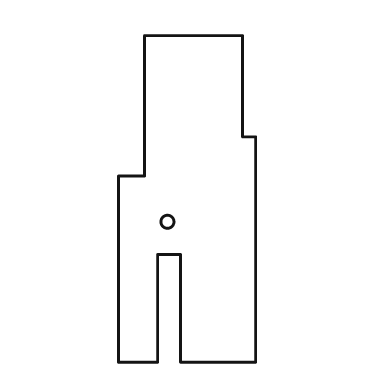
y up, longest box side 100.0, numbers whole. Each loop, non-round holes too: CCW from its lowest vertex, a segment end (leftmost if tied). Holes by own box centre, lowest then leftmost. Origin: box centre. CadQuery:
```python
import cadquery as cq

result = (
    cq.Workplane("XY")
    .moveTo(-21.0, -50.0)
    .lineTo(-9.0, -50.0)
    .lineTo(-9.0, -17.0)
    .lineTo(-2.0, -17.0)
    .lineTo(-2.0, -50.0)
    .lineTo(21.0, -50.0)
    .lineTo(21.0, 19.0)
    .lineTo(17.0, 19.0)
    .lineTo(17.0, 50.0)
    .lineTo(-13.0, 50.0)
    .lineTo(-13.0, 7.0)
    .lineTo(-21.0, 7.0)
    .close()
    .moveTo(-6.0, -7.0)
    .circle(2.0)
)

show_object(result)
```